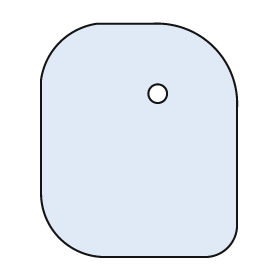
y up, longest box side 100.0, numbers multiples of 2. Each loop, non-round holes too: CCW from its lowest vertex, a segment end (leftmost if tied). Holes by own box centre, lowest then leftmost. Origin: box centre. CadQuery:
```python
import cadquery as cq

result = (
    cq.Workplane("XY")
    .moveTo(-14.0, -50.0)
    .lineTo(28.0, -50.0)
    .threePointArc((38.0, -46.0), (42.0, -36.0))
    .lineTo(42.0, 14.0)
    .threePointArc((32.0, 40.0), (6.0, 50.0))
    .lineTo(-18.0, 50.0)
    .threePointArc((-34.0, 42.0), (-42.0, 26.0))
    .lineTo(-42.0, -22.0)
    .threePointArc((-34.0, -42.0), (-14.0, -50.0))
    .close()
    .moveTo(8.0, 20.0)
    .circle(4.0)
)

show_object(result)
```